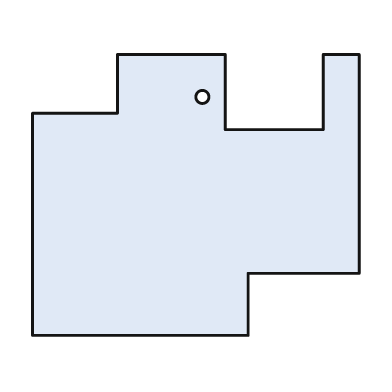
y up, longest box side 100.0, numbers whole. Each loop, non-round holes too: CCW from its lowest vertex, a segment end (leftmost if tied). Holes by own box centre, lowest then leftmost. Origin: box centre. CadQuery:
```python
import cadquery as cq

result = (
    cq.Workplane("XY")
    .moveTo(-50.0, -43.0)
    .lineTo(16.0, -43.0)
    .lineTo(16.0, -24.0)
    .lineTo(50.0, -24.0)
    .lineTo(50.0, 43.0)
    .lineTo(39.0, 43.0)
    .lineTo(39.0, 20.0)
    .lineTo(9.0, 20.0)
    .lineTo(9.0, 43.0)
    .lineTo(-24.0, 43.0)
    .lineTo(-24.0, 25.0)
    .lineTo(-50.0, 25.0)
    .close()
    .moveTo(2.0, 30.0)
    .circle(2.0)
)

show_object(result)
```